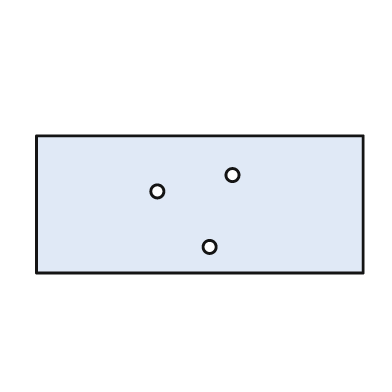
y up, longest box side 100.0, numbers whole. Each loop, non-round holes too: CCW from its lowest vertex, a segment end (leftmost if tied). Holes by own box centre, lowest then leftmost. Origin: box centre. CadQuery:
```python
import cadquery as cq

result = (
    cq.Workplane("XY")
    .moveTo(-50.0, -21.0)
    .lineTo(50.0, -21.0)
    .lineTo(50.0, 21.0)
    .lineTo(-50.0, 21.0)
    .close()
    .moveTo(3.0, -13.0)
    .circle(2.0)
    .moveTo(-13.0, 4.0)
    .circle(2.0)
    .moveTo(10.0, 9.0)
    .circle(2.0)
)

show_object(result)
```